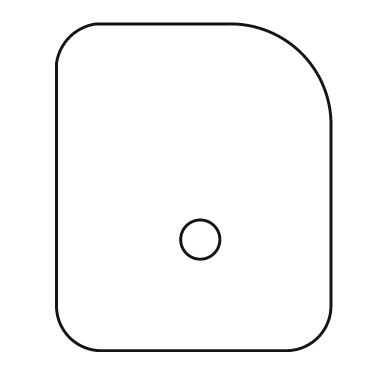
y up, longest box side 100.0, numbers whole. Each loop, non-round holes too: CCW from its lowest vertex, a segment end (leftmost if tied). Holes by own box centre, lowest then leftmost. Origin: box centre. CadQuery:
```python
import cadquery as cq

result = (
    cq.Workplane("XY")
    .moveTo(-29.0, -50.0)
    .lineTo(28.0, -50.0)
    .threePointArc((38.0, -46.0), (42.0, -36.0))
    .lineTo(42.0, 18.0)
    .threePointArc((33.0, 41.0), (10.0, 50.0))
    .lineTo(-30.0, 50.0)
    .threePointArc((-38.0, 46.0), (-42.0, 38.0))
    .lineTo(-42.0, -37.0)
    .threePointArc((-38.0, -46.0), (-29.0, -50.0))
    .close()
    .moveTo(2.0, -16.0)
    .circle(6.0)
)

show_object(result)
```